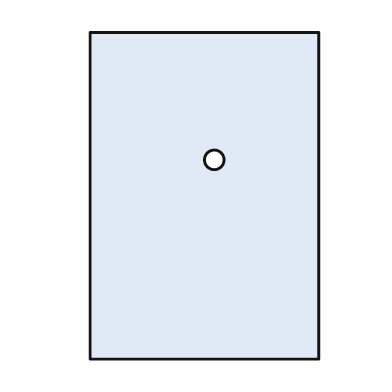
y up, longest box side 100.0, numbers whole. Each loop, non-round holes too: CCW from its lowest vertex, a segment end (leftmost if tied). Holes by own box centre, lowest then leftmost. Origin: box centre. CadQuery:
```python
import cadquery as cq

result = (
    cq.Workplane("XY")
    .moveTo(-35.0, -50.0)
    .lineTo(35.0, -50.0)
    .lineTo(35.0, 50.0)
    .lineTo(-35.0, 50.0)
    .close()
    .moveTo(3.0, 11.0)
    .circle(3.0)
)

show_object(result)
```